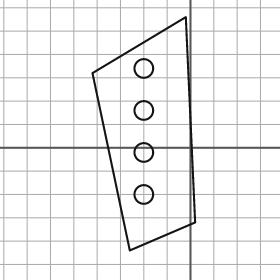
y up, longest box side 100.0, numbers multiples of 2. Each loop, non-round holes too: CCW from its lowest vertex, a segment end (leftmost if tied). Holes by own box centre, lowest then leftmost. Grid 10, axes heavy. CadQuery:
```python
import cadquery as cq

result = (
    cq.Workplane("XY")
    .moveTo(-26.0, -44.0)
    .lineTo(2.0, -32.0)
    .lineTo(-2.0, 56.0)
    .lineTo(-42.0, 32.0)
    .close()
    .moveTo(-20.0, -20.0)
    .circle(4.0)
    .moveTo(-20.0, -2.0)
    .circle(4.0)
    .moveTo(-20.0, 16.0)
    .circle(4.0)
    .moveTo(-20.0, 34.0)
    .circle(4.0)
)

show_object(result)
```